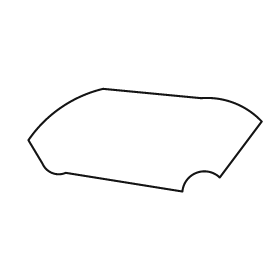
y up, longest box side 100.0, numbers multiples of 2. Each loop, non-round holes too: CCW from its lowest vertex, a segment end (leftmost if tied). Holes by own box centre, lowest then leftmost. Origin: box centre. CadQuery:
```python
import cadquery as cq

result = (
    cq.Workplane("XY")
    .moveTo(16.0, -22.0)
    .threePointArc((22.0, -14.0), (32.0, -16.0))
    .lineTo(50.0, 8.0)
    .threePointArc((38.0, 16.0), (24.0, 18.0))
    .lineTo(-18.0, 22.0)
    .threePointArc((-36.0, 14.0), (-50.0, 0.0))
    .lineTo(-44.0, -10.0)
    .threePointArc((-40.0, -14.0), (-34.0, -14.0))
    .close()
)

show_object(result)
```